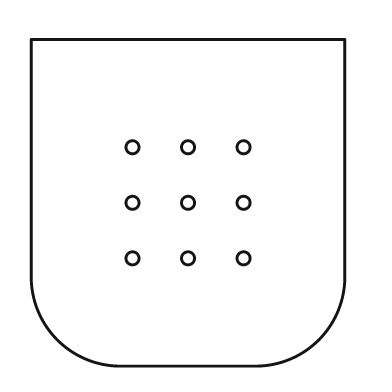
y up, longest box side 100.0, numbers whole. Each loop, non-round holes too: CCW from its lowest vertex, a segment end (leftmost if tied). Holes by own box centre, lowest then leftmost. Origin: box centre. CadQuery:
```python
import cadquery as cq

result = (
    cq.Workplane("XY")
    .moveTo(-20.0, -50.0)
    .lineTo(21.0, -50.0)
    .threePointArc((40.0, -42.0), (48.0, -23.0))
    .lineTo(48.0, 50.0)
    .lineTo(-48.0, 50.0)
    .lineTo(-48.0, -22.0)
    .threePointArc((-40.0, -42.0), (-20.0, -50.0))
    .close()
    .moveTo(-17.0, -17.0)
    .circle(2.0)
    .moveTo(0.0, -17.0)
    .circle(2.0)
    .moveTo(17.0, -17.0)
    .circle(2.0)
    .moveTo(-17.0, 0.0)
    .circle(2.0)
    .moveTo(0.0, 0.0)
    .circle(2.0)
    .moveTo(17.0, 0.0)
    .circle(2.0)
    .moveTo(-17.0, 17.0)
    .circle(2.0)
    .moveTo(0.0, 17.0)
    .circle(2.0)
    .moveTo(17.0, 17.0)
    .circle(2.0)
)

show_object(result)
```